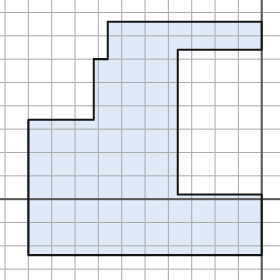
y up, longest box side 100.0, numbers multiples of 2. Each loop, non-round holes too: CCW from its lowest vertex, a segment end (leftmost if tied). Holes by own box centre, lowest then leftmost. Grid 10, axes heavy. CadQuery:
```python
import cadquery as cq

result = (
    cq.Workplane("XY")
    .moveTo(-100.0, -24.0)
    .lineTo(0.0, -24.0)
    .lineTo(0.0, 2.0)
    .lineTo(-36.0, 2.0)
    .lineTo(-36.0, 64.0)
    .lineTo(0.0, 64.0)
    .lineTo(0.0, 76.0)
    .lineTo(-66.0, 76.0)
    .lineTo(-66.0, 60.0)
    .lineTo(-72.0, 60.0)
    .lineTo(-72.0, 34.0)
    .lineTo(-100.0, 34.0)
    .close()
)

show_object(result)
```